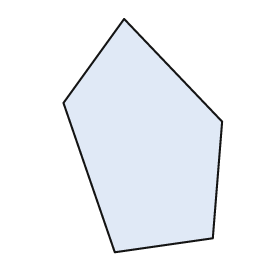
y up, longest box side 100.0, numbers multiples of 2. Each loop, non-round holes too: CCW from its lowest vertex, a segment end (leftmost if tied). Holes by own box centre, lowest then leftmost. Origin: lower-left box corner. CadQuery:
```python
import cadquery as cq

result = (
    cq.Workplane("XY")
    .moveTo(22.0, 0.0)
    .lineTo(64.0, 6.0)
    .lineTo(68.0, 56.0)
    .lineTo(26.0, 100.0)
    .lineTo(0.0, 64.0)
    .close()
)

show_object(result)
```